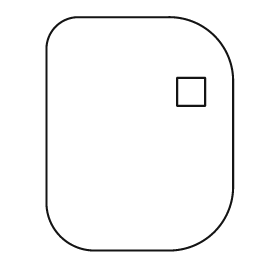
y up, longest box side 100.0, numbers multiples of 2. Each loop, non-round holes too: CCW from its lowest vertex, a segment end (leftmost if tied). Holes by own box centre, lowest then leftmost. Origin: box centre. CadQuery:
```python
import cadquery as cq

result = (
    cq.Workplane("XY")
    .moveTo(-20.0, -50.0)
    .lineTo(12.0, -50.0)
    .threePointArc((32.0, -42.0), (40.0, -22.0))
    .lineTo(40.0, 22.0)
    .threePointArc((32.0, 42.0), (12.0, 50.0))
    .lineTo(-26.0, 50.0)
    .threePointArc((-36.0, 46.0), (-40.0, 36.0))
    .lineTo(-40.0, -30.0)
    .threePointArc((-34.0, -44.0), (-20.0, -50.0))
    .close()
    .moveTo(16.0, 12.0)
    .lineTo(28.0, 12.0)
    .lineTo(28.0, 24.0)
    .lineTo(16.0, 24.0)
    .close()
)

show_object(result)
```